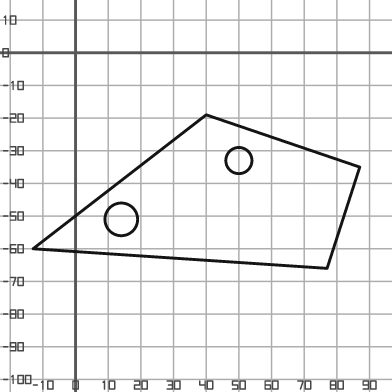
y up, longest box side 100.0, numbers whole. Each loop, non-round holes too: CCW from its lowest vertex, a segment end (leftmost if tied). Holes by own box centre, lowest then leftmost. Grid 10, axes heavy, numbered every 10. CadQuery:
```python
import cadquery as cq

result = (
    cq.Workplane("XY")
    .moveTo(77.0, -66.0)
    .lineTo(87.0, -35.0)
    .lineTo(40.0, -19.0)
    .lineTo(-13.0, -60.0)
    .close()
    .moveTo(14.0, -51.0)
    .circle(5.0)
    .moveTo(50.0, -33.0)
    .circle(4.0)
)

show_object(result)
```